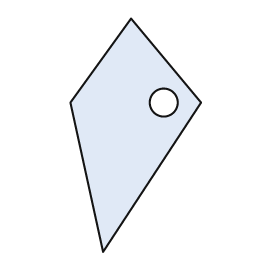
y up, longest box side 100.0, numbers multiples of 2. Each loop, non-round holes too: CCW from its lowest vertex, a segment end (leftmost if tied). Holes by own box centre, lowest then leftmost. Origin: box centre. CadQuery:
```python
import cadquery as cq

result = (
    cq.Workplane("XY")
    .moveTo(-14.0, -50.0)
    .lineTo(28.0, 14.0)
    .lineTo(-2.0, 50.0)
    .lineTo(-28.0, 14.0)
    .close()
    .moveTo(12.0, 14.0)
    .circle(6.0)
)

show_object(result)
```